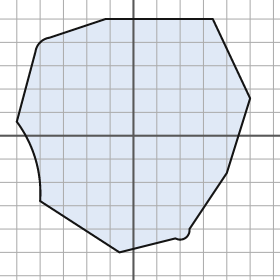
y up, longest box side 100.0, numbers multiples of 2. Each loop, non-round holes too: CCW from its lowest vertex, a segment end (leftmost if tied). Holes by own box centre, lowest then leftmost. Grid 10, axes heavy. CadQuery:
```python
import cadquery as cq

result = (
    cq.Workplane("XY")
    .moveTo(-6.0, -50.0)
    .lineTo(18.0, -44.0)
    .threePointArc((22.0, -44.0), (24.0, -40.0))
    .lineTo(40.0, -16.0)
    .lineTo(50.0, 16.0)
    .lineTo(34.0, 50.0)
    .lineTo(-12.0, 50.0)
    .lineTo(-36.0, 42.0)
    .threePointArc((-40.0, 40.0), (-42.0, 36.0))
    .lineTo(-50.0, 6.0)
    .threePointArc((-42.0, -10.0), (-40.0, -28.0))
    .close()
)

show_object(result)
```